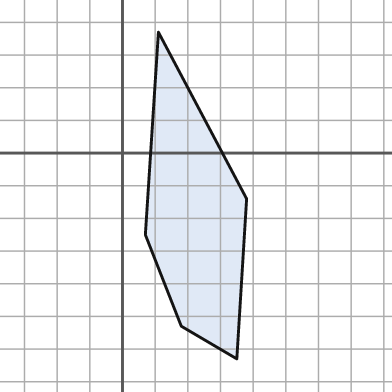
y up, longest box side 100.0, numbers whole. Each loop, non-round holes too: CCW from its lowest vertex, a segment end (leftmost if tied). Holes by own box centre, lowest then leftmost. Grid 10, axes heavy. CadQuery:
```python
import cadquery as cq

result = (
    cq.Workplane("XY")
    .moveTo(35.0, -63.0)
    .lineTo(38.0, -14.0)
    .lineTo(11.0, 37.0)
    .lineTo(7.0, -25.0)
    .lineTo(18.0, -53.0)
    .close()
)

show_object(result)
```